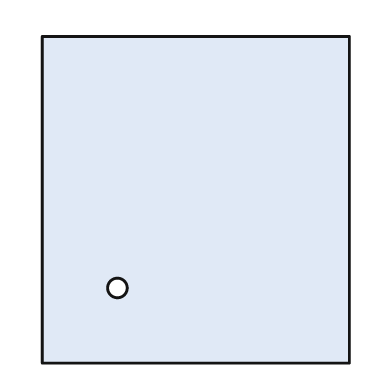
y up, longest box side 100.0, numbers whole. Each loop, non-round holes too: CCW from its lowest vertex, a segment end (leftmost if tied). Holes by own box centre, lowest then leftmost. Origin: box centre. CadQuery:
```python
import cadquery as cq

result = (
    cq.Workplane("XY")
    .moveTo(-47.0, -50.0)
    .lineTo(47.0, -50.0)
    .lineTo(47.0, 50.0)
    .lineTo(-47.0, 50.0)
    .close()
    .moveTo(-24.0, -27.0)
    .circle(3.0)
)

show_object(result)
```